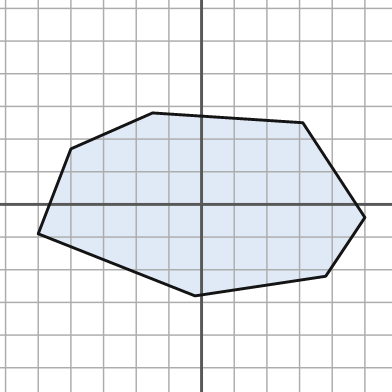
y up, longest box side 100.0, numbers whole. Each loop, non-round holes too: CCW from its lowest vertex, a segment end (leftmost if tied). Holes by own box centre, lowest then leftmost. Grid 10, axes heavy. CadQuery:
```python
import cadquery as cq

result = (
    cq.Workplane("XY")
    .moveTo(-2.0, -28.0)
    .lineTo(38.0, -22.0)
    .lineTo(50.0, -4.0)
    .lineTo(31.0, 25.0)
    .lineTo(-15.0, 28.0)
    .lineTo(-40.0, 17.0)
    .lineTo(-50.0, -9.0)
    .close()
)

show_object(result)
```